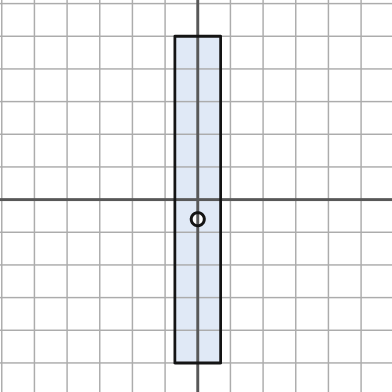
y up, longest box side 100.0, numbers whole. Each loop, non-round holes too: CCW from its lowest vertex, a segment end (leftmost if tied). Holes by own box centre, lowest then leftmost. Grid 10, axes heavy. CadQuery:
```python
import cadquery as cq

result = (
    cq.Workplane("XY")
    .moveTo(-7.0, -50.0)
    .lineTo(7.0, -50.0)
    .lineTo(7.0, 50.0)
    .lineTo(-7.0, 50.0)
    .close()
    .moveTo(0.0, -6.0)
    .circle(2.0)
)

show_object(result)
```